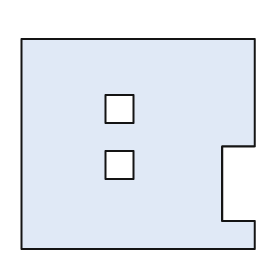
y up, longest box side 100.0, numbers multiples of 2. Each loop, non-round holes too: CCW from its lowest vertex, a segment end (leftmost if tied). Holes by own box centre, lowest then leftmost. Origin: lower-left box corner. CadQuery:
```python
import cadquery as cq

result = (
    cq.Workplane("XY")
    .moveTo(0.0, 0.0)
    .lineTo(100.0, 0.0)
    .lineTo(100.0, 12.0)
    .lineTo(86.0, 12.0)
    .lineTo(86.0, 44.0)
    .lineTo(100.0, 44.0)
    .lineTo(100.0, 90.0)
    .lineTo(0.0, 90.0)
    .close()
    .moveTo(36.0, 30.0)
    .lineTo(48.0, 30.0)
    .lineTo(48.0, 42.0)
    .lineTo(36.0, 42.0)
    .close()
    .moveTo(36.0, 54.0)
    .lineTo(48.0, 54.0)
    .lineTo(48.0, 66.0)
    .lineTo(36.0, 66.0)
    .close()
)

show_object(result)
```